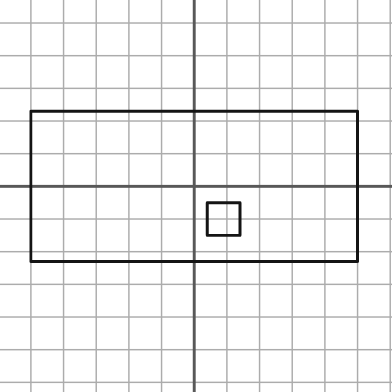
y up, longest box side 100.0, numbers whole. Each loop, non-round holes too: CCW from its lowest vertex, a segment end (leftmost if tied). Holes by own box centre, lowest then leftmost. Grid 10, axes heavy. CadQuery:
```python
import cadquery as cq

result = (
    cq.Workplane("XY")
    .moveTo(-50.0, -23.0)
    .lineTo(50.0, -23.0)
    .lineTo(50.0, 23.0)
    .lineTo(-50.0, 23.0)
    .close()
    .moveTo(4.0, -15.0)
    .lineTo(14.0, -15.0)
    .lineTo(14.0, -5.0)
    .lineTo(4.0, -5.0)
    .close()
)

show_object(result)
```